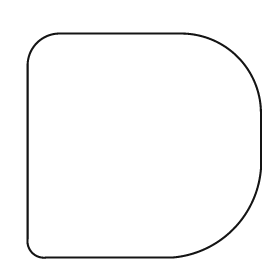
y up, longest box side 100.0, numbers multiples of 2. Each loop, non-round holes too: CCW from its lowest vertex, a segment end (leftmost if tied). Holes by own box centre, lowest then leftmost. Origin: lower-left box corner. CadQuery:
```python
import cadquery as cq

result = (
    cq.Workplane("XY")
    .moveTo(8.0, 0.0)
    .lineTo(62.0, 0.0)
    .threePointArc((88.0, 12.0), (100.0, 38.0))
    .lineTo(100.0, 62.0)
    .threePointArc((90.0, 86.0), (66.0, 96.0))
    .lineTo(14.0, 96.0)
    .threePointArc((4.0, 92.0), (0.0, 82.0))
    .lineTo(0.0, 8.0)
    .threePointArc((2.0, 2.0), (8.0, 0.0))
    .close()
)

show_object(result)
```